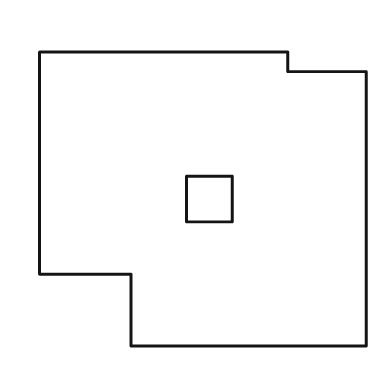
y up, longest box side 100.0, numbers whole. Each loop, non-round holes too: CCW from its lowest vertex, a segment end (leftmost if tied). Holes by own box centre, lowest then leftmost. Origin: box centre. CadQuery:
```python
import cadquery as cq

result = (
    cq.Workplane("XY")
    .moveTo(-22.0, -45.0)
    .lineTo(50.0, -45.0)
    .lineTo(50.0, 39.0)
    .lineTo(26.0, 39.0)
    .lineTo(26.0, 45.0)
    .lineTo(-50.0, 45.0)
    .lineTo(-50.0, -23.0)
    .lineTo(-22.0, -23.0)
    .close()
    .moveTo(-5.0, -7.0)
    .lineTo(9.0, -7.0)
    .lineTo(9.0, 7.0)
    .lineTo(-5.0, 7.0)
    .close()
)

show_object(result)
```